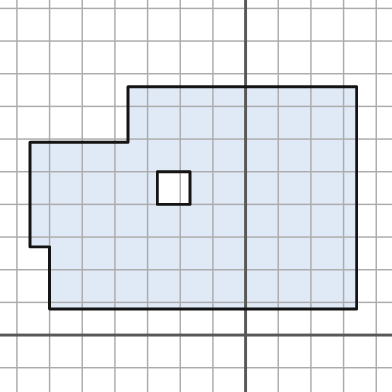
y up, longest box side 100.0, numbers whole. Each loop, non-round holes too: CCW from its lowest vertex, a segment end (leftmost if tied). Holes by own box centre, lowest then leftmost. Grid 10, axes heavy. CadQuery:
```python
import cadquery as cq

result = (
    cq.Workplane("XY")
    .moveTo(-60.0, 8.0)
    .lineTo(34.0, 8.0)
    .lineTo(34.0, 76.0)
    .lineTo(-36.0, 76.0)
    .lineTo(-36.0, 59.0)
    .lineTo(-66.0, 59.0)
    .lineTo(-66.0, 27.0)
    .lineTo(-60.0, 27.0)
    .close()
    .moveTo(-27.0, 40.0)
    .lineTo(-17.0, 40.0)
    .lineTo(-17.0, 50.0)
    .lineTo(-27.0, 50.0)
    .close()
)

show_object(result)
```